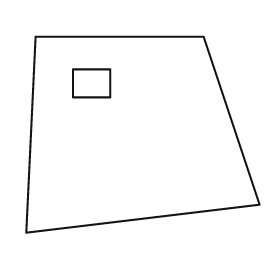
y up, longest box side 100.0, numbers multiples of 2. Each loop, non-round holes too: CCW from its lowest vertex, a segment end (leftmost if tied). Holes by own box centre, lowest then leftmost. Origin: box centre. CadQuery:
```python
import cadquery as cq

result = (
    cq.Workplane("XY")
    .moveTo(-50.0, -42.0)
    .lineTo(50.0, -30.0)
    .lineTo(26.0, 42.0)
    .lineTo(-46.0, 42.0)
    .close()
    .moveTo(-30.0, 16.0)
    .lineTo(-14.0, 16.0)
    .lineTo(-14.0, 28.0)
    .lineTo(-30.0, 28.0)
    .close()
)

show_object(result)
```